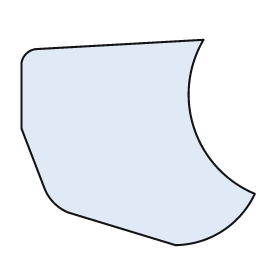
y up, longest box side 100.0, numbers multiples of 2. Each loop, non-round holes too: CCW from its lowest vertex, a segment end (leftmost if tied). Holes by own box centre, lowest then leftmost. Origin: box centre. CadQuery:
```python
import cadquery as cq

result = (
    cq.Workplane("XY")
    .moveTo(16.0, -44.0)
    .threePointArc((36.0, -38.0), (50.0, -22.0))
    .threePointArc((24.0, 6.0), (28.0, 44.0))
    .lineTo(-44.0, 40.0)
    .threePointArc((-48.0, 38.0), (-50.0, 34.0))
    .lineTo(-50.0, 6.0)
    .lineTo(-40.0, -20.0)
    .threePointArc((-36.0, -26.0), (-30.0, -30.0))
    .close()
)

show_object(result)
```